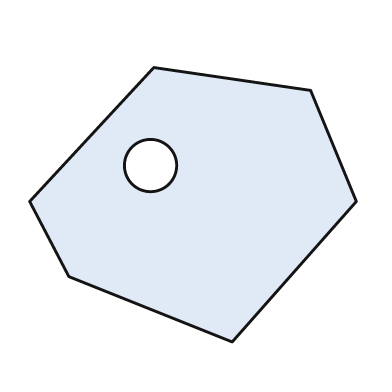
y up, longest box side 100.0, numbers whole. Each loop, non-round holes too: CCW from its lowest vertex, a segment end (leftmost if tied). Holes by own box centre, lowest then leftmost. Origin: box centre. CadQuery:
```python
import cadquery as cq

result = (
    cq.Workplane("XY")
    .moveTo(12.0, -42.0)
    .lineTo(50.0, 1.0)
    .lineTo(36.0, 35.0)
    .lineTo(-12.0, 42.0)
    .lineTo(-50.0, 1.0)
    .lineTo(-38.0, -22.0)
    .close()
    .moveTo(-13.0, 12.0)
    .circle(8.0)
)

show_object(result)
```